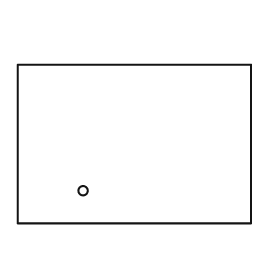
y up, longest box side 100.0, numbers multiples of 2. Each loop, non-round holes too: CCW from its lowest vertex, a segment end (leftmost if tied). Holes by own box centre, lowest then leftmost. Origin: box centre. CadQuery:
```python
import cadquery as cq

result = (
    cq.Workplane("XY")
    .moveTo(-50.0, -34.0)
    .lineTo(50.0, -34.0)
    .lineTo(50.0, 34.0)
    .lineTo(-50.0, 34.0)
    .close()
    .moveTo(-22.0, -20.0)
    .circle(2.0)
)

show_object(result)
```